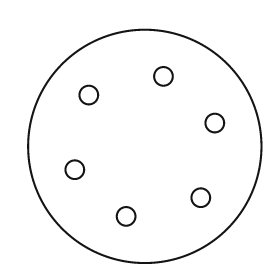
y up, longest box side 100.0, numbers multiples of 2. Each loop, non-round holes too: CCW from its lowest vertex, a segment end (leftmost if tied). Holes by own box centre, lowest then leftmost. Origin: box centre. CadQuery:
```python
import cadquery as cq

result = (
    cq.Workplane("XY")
    .moveTo(0.0, 0.0)
    .circle(50.0)
    .moveTo(-8.0, -30.0)
    .circle(4.0)
    .moveTo(24.0, -22.0)
    .circle(4.0)
    .moveTo(-30.0, -10.0)
    .circle(4.0)
    .moveTo(30.0, 10.0)
    .circle(4.0)
    .moveTo(-24.0, 22.0)
    .circle(4.0)
    .moveTo(8.0, 30.0)
    .circle(4.0)
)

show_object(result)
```